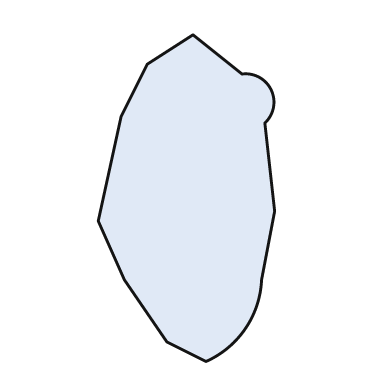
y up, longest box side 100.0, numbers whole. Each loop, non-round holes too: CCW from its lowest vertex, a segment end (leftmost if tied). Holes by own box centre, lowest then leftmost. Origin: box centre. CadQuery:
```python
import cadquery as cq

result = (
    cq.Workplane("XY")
    .moveTo(6.0, -50.0)
    .threePointArc((18.0, -40.0), (23.0, -25.0))
    .lineTo(27.0, -4.0)
    .lineTo(24.0, 23.0)
    .threePointArc((26.0, 33.0), (17.0, 38.0))
    .lineTo(2.0, 50.0)
    .lineTo(-12.0, 41.0)
    .lineTo(-20.0, 25.0)
    .lineTo(-27.0, -7.0)
    .lineTo(-19.0, -25.0)
    .lineTo(-6.0, -44.0)
    .close()
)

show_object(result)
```